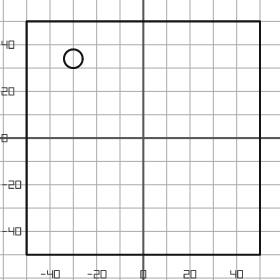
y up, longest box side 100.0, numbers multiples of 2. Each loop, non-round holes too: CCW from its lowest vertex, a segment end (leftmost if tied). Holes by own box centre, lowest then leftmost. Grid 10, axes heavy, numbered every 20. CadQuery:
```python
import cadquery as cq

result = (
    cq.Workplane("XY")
    .moveTo(-50.0, -50.0)
    .lineTo(50.0, -50.0)
    .lineTo(50.0, 50.0)
    .lineTo(-50.0, 50.0)
    .close()
    .moveTo(-30.0, 34.0)
    .circle(4.0)
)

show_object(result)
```